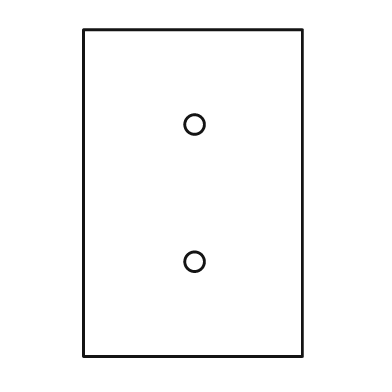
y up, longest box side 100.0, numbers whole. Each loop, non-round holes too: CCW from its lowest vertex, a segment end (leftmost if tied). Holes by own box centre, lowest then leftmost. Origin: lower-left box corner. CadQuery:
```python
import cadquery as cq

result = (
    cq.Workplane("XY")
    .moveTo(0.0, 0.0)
    .lineTo(67.0, 0.0)
    .lineTo(67.0, 100.0)
    .lineTo(0.0, 100.0)
    .close()
    .moveTo(34.0, 29.0)
    .circle(3.0)
    .moveTo(34.0, 71.0)
    .circle(3.0)
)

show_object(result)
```